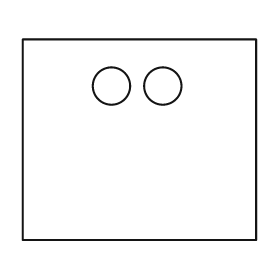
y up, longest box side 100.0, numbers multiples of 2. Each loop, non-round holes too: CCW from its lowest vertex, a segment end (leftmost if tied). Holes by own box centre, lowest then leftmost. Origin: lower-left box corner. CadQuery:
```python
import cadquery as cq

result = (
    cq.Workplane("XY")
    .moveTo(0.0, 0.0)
    .lineTo(100.0, 0.0)
    .lineTo(100.0, 86.0)
    .lineTo(0.0, 86.0)
    .close()
    .moveTo(38.0, 66.0)
    .circle(8.0)
    .moveTo(60.0, 66.0)
    .circle(8.0)
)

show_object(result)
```